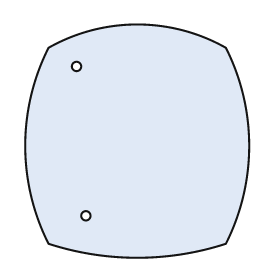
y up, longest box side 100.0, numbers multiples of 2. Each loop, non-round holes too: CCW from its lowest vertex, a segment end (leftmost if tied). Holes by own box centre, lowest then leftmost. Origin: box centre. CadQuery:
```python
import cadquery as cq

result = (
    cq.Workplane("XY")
    .moveTo(-38.0, -44.0)
    .threePointArc((0.0, -50.0), (38.0, -44.0))
    .threePointArc((48.0, -2.0), (38.0, 40.0))
    .threePointArc((0.0, 50.0), (-38.0, 40.0))
    .threePointArc((-48.0, -2.0), (-38.0, -44.0))
    .close()
    .moveTo(-22.0, -32.0)
    .circle(2.0)
    .moveTo(-26.0, 32.0)
    .circle(2.0)
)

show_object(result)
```